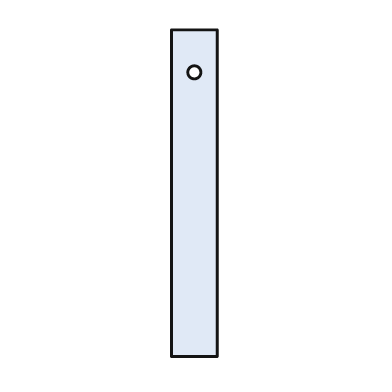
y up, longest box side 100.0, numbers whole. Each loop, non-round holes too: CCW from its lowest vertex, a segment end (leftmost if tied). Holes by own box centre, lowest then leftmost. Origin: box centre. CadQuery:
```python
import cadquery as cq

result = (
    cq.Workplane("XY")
    .moveTo(-7.0, -50.0)
    .lineTo(7.0, -50.0)
    .lineTo(7.0, 50.0)
    .lineTo(-7.0, 50.0)
    .close()
    .moveTo(0.0, 37.0)
    .circle(2.0)
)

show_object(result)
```